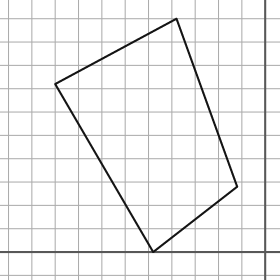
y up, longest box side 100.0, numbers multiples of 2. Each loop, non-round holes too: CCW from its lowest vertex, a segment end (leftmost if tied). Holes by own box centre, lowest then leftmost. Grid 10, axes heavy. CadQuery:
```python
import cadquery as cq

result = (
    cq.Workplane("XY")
    .moveTo(-48.0, 0.0)
    .lineTo(-12.0, 28.0)
    .lineTo(-38.0, 100.0)
    .lineTo(-90.0, 72.0)
    .close()
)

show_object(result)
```